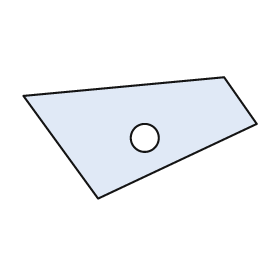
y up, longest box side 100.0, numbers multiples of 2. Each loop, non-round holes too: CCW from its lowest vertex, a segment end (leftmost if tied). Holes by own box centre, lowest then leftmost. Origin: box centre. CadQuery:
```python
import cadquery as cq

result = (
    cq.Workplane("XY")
    .moveTo(-18.0, -26.0)
    .lineTo(50.0, 6.0)
    .lineTo(36.0, 26.0)
    .lineTo(-50.0, 18.0)
    .close()
    .moveTo(2.0, 0.0)
    .circle(6.0)
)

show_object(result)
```